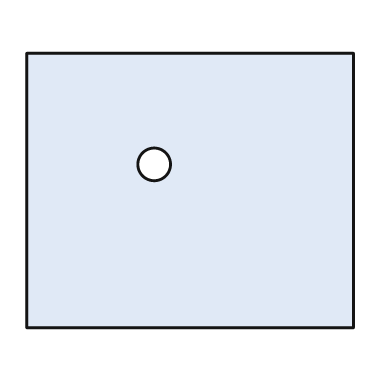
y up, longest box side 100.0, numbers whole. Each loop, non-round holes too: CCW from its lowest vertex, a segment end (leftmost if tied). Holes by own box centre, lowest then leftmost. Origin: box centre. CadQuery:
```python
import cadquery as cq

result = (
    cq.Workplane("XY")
    .moveTo(-50.0, -42.0)
    .lineTo(50.0, -42.0)
    .lineTo(50.0, 42.0)
    .lineTo(-50.0, 42.0)
    .close()
    .moveTo(-11.0, 8.0)
    .circle(5.0)
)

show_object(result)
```